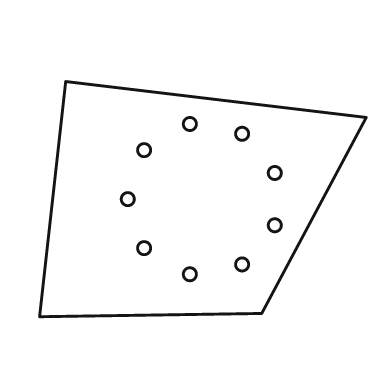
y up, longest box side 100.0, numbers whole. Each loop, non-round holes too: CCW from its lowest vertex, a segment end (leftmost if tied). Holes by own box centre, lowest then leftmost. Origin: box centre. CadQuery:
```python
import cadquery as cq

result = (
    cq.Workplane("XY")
    .moveTo(-50.0, -36.0)
    .lineTo(18.0, -35.0)
    .lineTo(50.0, 25.0)
    .lineTo(-42.0, 36.0)
    .close()
    .moveTo(-4.0, -23.0)
    .circle(2.0)
    .moveTo(12.0, -20.0)
    .circle(2.0)
    .moveTo(-18.0, -15.0)
    .circle(2.0)
    .moveTo(22.0, -8.0)
    .circle(2.0)
    .moveTo(-23.0, 0.0)
    .circle(2.0)
    .moveTo(22.0, 8.0)
    .circle(2.0)
    .moveTo(-18.0, 15.0)
    .circle(2.0)
    .moveTo(12.0, 20.0)
    .circle(2.0)
    .moveTo(-4.0, 23.0)
    .circle(2.0)
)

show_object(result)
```